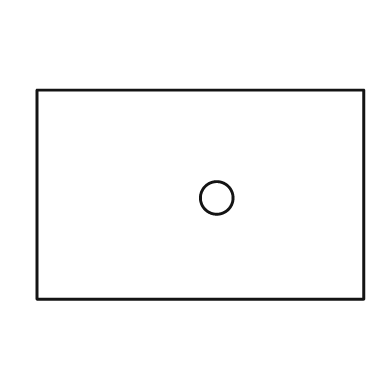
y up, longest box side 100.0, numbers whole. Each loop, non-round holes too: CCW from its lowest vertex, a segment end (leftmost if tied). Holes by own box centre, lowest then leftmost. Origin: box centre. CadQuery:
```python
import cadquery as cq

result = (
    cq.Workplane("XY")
    .moveTo(-50.0, -32.0)
    .lineTo(50.0, -32.0)
    .lineTo(50.0, 32.0)
    .lineTo(-50.0, 32.0)
    .close()
    .moveTo(5.0, -1.0)
    .circle(5.0)
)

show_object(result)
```